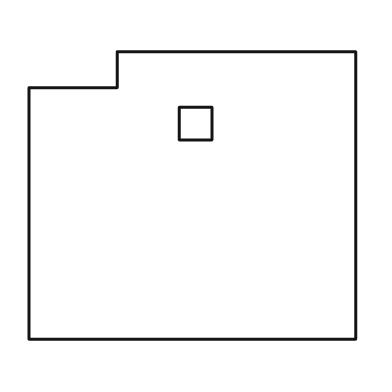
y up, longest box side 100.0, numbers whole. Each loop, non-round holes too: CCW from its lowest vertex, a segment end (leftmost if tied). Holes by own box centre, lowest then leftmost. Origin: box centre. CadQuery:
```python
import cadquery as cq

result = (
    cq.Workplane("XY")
    .moveTo(-50.0, -44.0)
    .lineTo(50.0, -44.0)
    .lineTo(50.0, 44.0)
    .lineTo(-23.0, 44.0)
    .lineTo(-23.0, 33.0)
    .lineTo(-50.0, 33.0)
    .close()
    .moveTo(-4.0, 17.0)
    .lineTo(6.0, 17.0)
    .lineTo(6.0, 27.0)
    .lineTo(-4.0, 27.0)
    .close()
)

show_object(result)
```